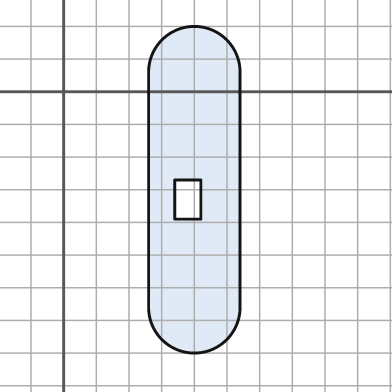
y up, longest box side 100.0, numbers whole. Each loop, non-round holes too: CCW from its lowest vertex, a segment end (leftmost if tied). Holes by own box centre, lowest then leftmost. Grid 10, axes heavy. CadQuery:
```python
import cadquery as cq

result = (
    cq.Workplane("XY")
    .moveTo(26.0, -66.0)
    .threePointArc((40.0, -80.0), (54.0, -66.0))
    .lineTo(54.0, 6.0)
    .threePointArc((40.0, 20.0), (26.0, 6.0))
    .close()
    .moveTo(34.0, -39.0)
    .lineTo(42.0, -39.0)
    .lineTo(42.0, -27.0)
    .lineTo(34.0, -27.0)
    .close()
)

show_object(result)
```